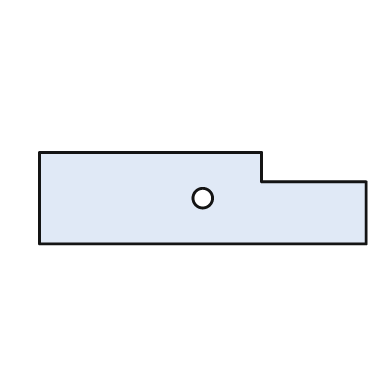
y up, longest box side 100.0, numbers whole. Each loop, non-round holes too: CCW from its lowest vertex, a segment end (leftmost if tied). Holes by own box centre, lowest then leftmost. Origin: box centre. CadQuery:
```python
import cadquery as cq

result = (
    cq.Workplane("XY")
    .moveTo(-50.0, -14.0)
    .lineTo(50.0, -14.0)
    .lineTo(50.0, 5.0)
    .lineTo(18.0, 5.0)
    .lineTo(18.0, 14.0)
    .lineTo(-50.0, 14.0)
    .close()
    .moveTo(0.0, 0.0)
    .circle(3.0)
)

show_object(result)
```